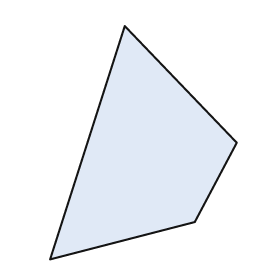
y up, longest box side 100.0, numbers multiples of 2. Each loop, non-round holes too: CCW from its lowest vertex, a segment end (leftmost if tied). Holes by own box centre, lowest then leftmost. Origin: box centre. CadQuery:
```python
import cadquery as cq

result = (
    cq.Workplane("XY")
    .moveTo(-40.0, -50.0)
    .lineTo(22.0, -34.0)
    .lineTo(40.0, 0.0)
    .lineTo(-8.0, 50.0)
    .close()
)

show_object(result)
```